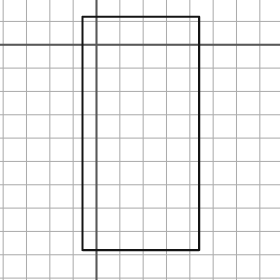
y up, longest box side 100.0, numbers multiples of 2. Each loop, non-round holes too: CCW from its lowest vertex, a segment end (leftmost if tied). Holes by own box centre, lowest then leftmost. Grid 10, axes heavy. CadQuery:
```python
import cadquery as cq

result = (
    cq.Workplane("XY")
    .moveTo(-6.0, -88.0)
    .lineTo(44.0, -88.0)
    .lineTo(44.0, 12.0)
    .lineTo(-6.0, 12.0)
    .close()
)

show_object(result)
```